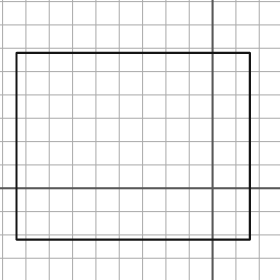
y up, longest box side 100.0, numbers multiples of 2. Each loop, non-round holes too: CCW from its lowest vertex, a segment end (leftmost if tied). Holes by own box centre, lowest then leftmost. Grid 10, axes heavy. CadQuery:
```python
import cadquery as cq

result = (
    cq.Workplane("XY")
    .moveTo(-84.0, -22.0)
    .lineTo(16.0, -22.0)
    .lineTo(16.0, 58.0)
    .lineTo(-84.0, 58.0)
    .close()
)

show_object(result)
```